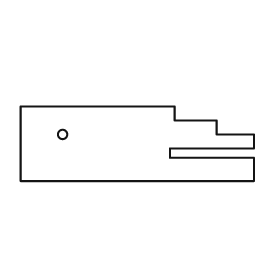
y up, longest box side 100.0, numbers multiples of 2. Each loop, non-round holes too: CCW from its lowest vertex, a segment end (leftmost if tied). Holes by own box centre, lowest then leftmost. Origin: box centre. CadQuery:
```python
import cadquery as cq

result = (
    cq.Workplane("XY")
    .moveTo(-50.0, -16.0)
    .lineTo(50.0, -16.0)
    .lineTo(50.0, -6.0)
    .lineTo(14.0, -6.0)
    .lineTo(14.0, -2.0)
    .lineTo(50.0, -2.0)
    .lineTo(50.0, 4.0)
    .lineTo(34.0, 4.0)
    .lineTo(34.0, 10.0)
    .lineTo(16.0, 10.0)
    .lineTo(16.0, 16.0)
    .lineTo(-50.0, 16.0)
    .close()
    .moveTo(-32.0, 4.0)
    .circle(2.0)
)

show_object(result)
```